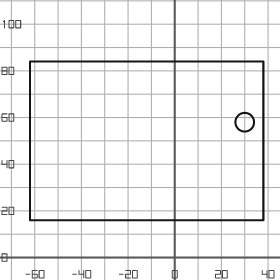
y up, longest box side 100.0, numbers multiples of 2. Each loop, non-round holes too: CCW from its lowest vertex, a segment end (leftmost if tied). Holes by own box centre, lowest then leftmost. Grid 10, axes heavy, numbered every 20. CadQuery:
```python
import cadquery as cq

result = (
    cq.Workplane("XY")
    .moveTo(-62.0, 16.0)
    .lineTo(38.0, 16.0)
    .lineTo(38.0, 84.0)
    .lineTo(-62.0, 84.0)
    .close()
    .moveTo(30.0, 58.0)
    .circle(4.0)
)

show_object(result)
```